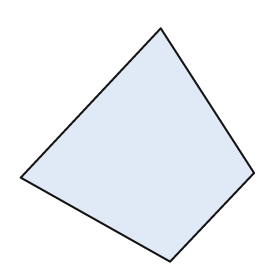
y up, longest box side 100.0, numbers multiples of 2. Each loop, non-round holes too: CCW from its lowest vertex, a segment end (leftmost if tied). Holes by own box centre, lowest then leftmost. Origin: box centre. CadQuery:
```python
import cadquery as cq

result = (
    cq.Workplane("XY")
    .moveTo(14.0, -50.0)
    .lineTo(50.0, -12.0)
    .lineTo(10.0, 50.0)
    .lineTo(-50.0, -14.0)
    .close()
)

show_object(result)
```